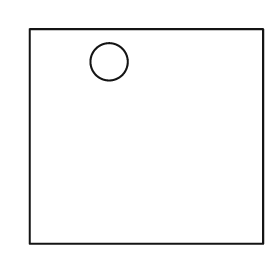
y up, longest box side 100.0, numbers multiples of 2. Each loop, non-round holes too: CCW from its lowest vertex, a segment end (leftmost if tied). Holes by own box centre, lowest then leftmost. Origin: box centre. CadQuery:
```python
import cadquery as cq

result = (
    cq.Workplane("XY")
    .moveTo(-50.0, -46.0)
    .lineTo(50.0, -46.0)
    .lineTo(50.0, 46.0)
    .lineTo(-50.0, 46.0)
    .close()
    .moveTo(-16.0, 32.0)
    .circle(8.0)
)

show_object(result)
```